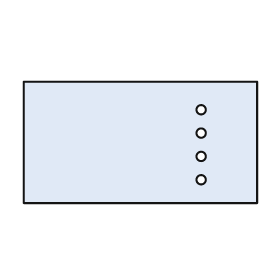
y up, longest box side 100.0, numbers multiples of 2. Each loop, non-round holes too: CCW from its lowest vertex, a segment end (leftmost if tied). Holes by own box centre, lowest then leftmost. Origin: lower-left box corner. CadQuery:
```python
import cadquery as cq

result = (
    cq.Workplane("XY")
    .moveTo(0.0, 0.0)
    .lineTo(100.0, 0.0)
    .lineTo(100.0, 52.0)
    .lineTo(0.0, 52.0)
    .close()
    .moveTo(76.0, 10.0)
    .circle(2.0)
    .moveTo(76.0, 20.0)
    .circle(2.0)
    .moveTo(76.0, 30.0)
    .circle(2.0)
    .moveTo(76.0, 40.0)
    .circle(2.0)
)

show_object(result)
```